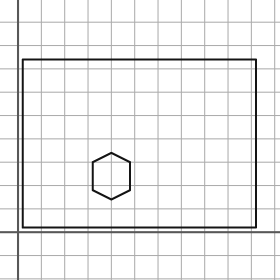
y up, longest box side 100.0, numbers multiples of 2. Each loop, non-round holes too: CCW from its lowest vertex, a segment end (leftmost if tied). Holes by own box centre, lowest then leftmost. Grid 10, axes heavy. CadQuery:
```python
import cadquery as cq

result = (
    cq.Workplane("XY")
    .moveTo(2.0, 2.0)
    .lineTo(102.0, 2.0)
    .lineTo(102.0, 74.0)
    .lineTo(2.0, 74.0)
    .close()
    .moveTo(40.0, 14.0)
    .lineTo(48.0, 18.0)
    .lineTo(48.0, 30.0)
    .lineTo(40.0, 34.0)
    .lineTo(32.0, 30.0)
    .lineTo(32.0, 18.0)
    .close()
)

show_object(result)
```